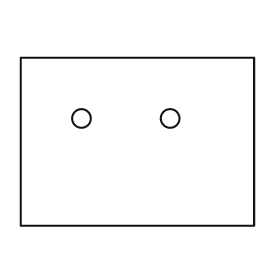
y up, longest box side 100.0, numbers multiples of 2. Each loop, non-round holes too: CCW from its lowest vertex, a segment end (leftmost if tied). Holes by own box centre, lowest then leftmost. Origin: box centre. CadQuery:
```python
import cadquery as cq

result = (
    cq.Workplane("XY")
    .moveTo(-50.0, -36.0)
    .lineTo(50.0, -36.0)
    .lineTo(50.0, 36.0)
    .lineTo(-50.0, 36.0)
    .close()
    .moveTo(-24.0, 10.0)
    .circle(4.0)
    .moveTo(14.0, 10.0)
    .circle(4.0)
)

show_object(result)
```